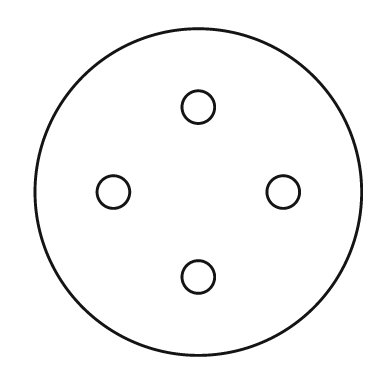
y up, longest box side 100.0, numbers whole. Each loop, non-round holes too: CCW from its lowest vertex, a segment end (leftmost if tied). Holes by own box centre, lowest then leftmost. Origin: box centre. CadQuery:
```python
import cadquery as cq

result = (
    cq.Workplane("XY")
    .moveTo(0.0, 0.0)
    .circle(50.0)
    .moveTo(0.0, -26.0)
    .circle(5.0)
    .moveTo(-26.0, 0.0)
    .circle(5.0)
    .moveTo(26.0, 0.0)
    .circle(5.0)
    .moveTo(0.0, 26.0)
    .circle(5.0)
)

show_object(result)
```